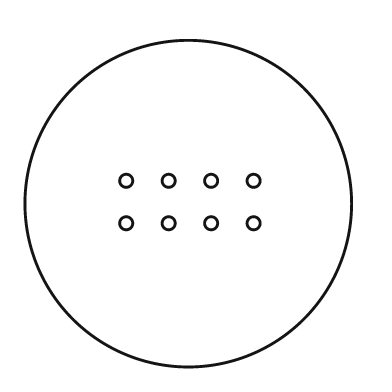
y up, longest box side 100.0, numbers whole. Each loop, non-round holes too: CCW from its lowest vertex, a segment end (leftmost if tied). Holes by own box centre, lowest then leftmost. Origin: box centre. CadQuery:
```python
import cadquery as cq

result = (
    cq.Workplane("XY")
    .moveTo(0.0, 0.0)
    .circle(50.0)
    .moveTo(-19.0, -6.0)
    .circle(2.0)
    .moveTo(-6.0, -6.0)
    .circle(2.0)
    .moveTo(7.0, -6.0)
    .circle(2.0)
    .moveTo(20.0, -6.0)
    .circle(2.0)
    .moveTo(-19.0, 7.0)
    .circle(2.0)
    .moveTo(-6.0, 7.0)
    .circle(2.0)
    .moveTo(7.0, 7.0)
    .circle(2.0)
    .moveTo(20.0, 7.0)
    .circle(2.0)
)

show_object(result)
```